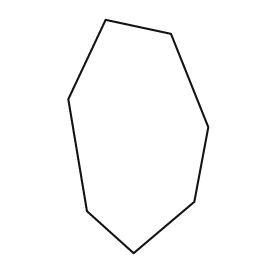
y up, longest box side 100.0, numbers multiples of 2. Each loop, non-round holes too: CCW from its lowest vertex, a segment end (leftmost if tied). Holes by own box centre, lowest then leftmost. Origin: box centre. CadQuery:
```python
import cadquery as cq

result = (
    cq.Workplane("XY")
    .moveTo(-2.0, -50.0)
    .lineTo(24.0, -28.0)
    .lineTo(30.0, 4.0)
    .lineTo(14.0, 44.0)
    .lineTo(-14.0, 50.0)
    .lineTo(-30.0, 16.0)
    .lineTo(-22.0, -32.0)
    .close()
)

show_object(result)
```